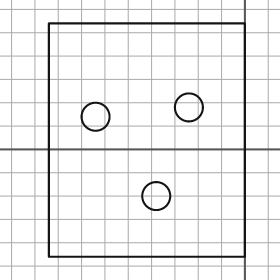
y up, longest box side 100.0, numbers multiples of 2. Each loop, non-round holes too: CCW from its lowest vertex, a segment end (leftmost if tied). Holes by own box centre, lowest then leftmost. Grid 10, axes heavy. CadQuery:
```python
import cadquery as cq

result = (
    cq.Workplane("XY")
    .moveTo(-84.0, -46.0)
    .lineTo(0.0, -46.0)
    .lineTo(0.0, 54.0)
    .lineTo(-84.0, 54.0)
    .close()
    .moveTo(-38.0, -20.0)
    .circle(6.0)
    .moveTo(-64.0, 14.0)
    .circle(6.0)
    .moveTo(-24.0, 18.0)
    .circle(6.0)
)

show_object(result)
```